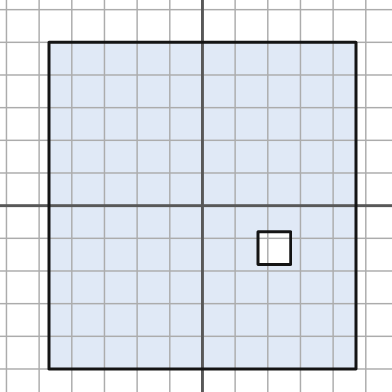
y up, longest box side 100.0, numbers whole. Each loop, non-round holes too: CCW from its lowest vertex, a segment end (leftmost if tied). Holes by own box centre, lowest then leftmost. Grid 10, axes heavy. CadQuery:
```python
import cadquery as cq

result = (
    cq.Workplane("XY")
    .moveTo(-47.0, -50.0)
    .lineTo(47.0, -50.0)
    .lineTo(47.0, 50.0)
    .lineTo(-47.0, 50.0)
    .close()
    .moveTo(17.0, -18.0)
    .lineTo(27.0, -18.0)
    .lineTo(27.0, -8.0)
    .lineTo(17.0, -8.0)
    .close()
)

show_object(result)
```